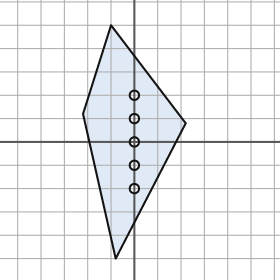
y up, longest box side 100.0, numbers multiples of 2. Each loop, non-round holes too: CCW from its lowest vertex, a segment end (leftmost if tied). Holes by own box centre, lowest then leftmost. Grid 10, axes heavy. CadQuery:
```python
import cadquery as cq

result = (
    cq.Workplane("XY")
    .moveTo(-8.0, -50.0)
    .lineTo(22.0, 8.0)
    .lineTo(-10.0, 50.0)
    .lineTo(-22.0, 12.0)
    .close()
    .moveTo(0.0, -20.0)
    .circle(2.0)
    .moveTo(0.0, -10.0)
    .circle(2.0)
    .moveTo(0.0, 0.0)
    .circle(2.0)
    .moveTo(0.0, 10.0)
    .circle(2.0)
    .moveTo(0.0, 20.0)
    .circle(2.0)
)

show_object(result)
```